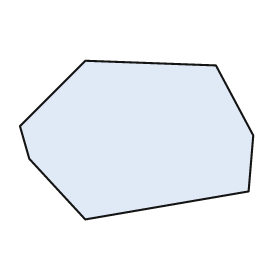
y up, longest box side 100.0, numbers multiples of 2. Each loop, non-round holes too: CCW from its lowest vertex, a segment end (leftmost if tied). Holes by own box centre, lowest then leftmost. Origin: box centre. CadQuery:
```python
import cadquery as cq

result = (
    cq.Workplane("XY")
    .moveTo(-22.0, -34.0)
    .lineTo(48.0, -22.0)
    .lineTo(50.0, 2.0)
    .lineTo(34.0, 32.0)
    .lineTo(-22.0, 34.0)
    .lineTo(-50.0, 6.0)
    .lineTo(-46.0, -8.0)
    .close()
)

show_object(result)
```